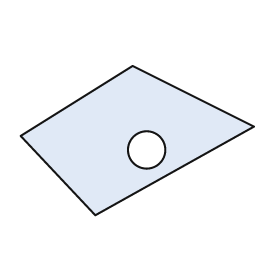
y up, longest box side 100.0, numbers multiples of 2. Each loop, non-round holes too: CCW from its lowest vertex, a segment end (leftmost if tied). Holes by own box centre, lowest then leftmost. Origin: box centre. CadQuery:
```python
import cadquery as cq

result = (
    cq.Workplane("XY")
    .moveTo(-18.0, -32.0)
    .lineTo(50.0, 6.0)
    .lineTo(-2.0, 32.0)
    .lineTo(-50.0, 2.0)
    .close()
    .moveTo(4.0, -4.0)
    .circle(8.0)
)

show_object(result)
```